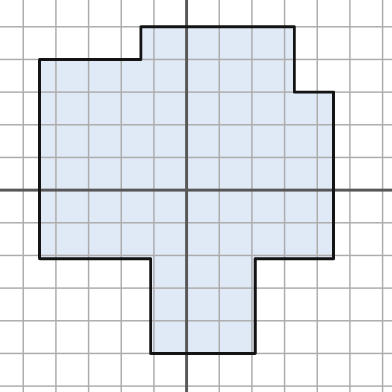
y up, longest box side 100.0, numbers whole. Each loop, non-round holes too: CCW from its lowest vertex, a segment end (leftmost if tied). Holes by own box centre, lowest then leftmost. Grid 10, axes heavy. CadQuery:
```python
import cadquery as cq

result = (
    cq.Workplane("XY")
    .moveTo(-11.0, -50.0)
    .lineTo(21.0, -50.0)
    .lineTo(21.0, -21.0)
    .lineTo(45.0, -21.0)
    .lineTo(45.0, 30.0)
    .lineTo(33.0, 30.0)
    .lineTo(33.0, 50.0)
    .lineTo(-14.0, 50.0)
    .lineTo(-14.0, 40.0)
    .lineTo(-45.0, 40.0)
    .lineTo(-45.0, -21.0)
    .lineTo(-11.0, -21.0)
    .close()
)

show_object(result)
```